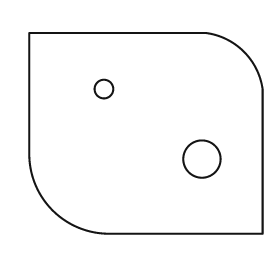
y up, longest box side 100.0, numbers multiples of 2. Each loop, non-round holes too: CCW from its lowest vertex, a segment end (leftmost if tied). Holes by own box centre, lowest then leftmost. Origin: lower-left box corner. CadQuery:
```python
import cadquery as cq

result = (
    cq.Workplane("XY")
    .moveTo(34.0, 0.0)
    .lineTo(100.0, 0.0)
    .lineTo(100.0, 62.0)
    .threePointArc((92.0, 78.0), (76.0, 86.0))
    .lineTo(0.0, 86.0)
    .lineTo(0.0, 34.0)
    .threePointArc((10.0, 10.0), (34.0, 0.0))
    .close()
    .moveTo(74.0, 32.0)
    .circle(8.0)
    .moveTo(32.0, 62.0)
    .circle(4.0)
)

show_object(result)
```